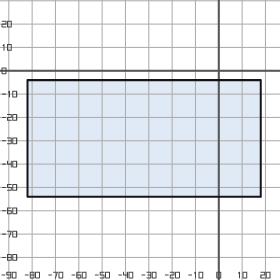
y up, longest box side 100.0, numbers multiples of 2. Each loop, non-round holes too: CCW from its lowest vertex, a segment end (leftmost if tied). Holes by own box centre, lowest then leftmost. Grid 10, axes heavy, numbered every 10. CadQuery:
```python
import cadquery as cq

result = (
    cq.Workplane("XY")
    .moveTo(-82.0, -54.0)
    .lineTo(18.0, -54.0)
    .lineTo(18.0, -4.0)
    .lineTo(-82.0, -4.0)
    .close()
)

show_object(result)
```